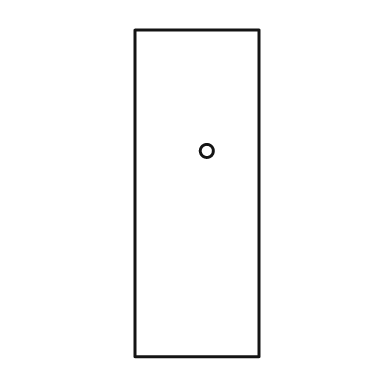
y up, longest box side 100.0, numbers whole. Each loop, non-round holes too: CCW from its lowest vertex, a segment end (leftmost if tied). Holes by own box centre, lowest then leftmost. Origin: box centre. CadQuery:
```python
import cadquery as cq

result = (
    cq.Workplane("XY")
    .moveTo(-19.0, -50.0)
    .lineTo(19.0, -50.0)
    .lineTo(19.0, 50.0)
    .lineTo(-19.0, 50.0)
    .close()
    .moveTo(3.0, 13.0)
    .circle(2.0)
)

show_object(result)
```